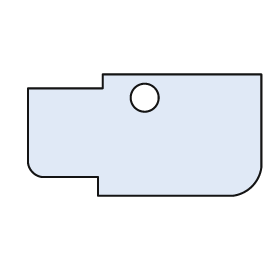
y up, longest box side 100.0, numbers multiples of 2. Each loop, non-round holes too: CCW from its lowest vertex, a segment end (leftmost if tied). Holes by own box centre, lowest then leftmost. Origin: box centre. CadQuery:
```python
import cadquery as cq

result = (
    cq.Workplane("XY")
    .moveTo(-20.0, -26.0)
    .lineTo(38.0, -26.0)
    .threePointArc((46.0, -22.0), (50.0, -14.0))
    .lineTo(50.0, 26.0)
    .lineTo(-18.0, 26.0)
    .lineTo(-18.0, 20.0)
    .lineTo(-50.0, 20.0)
    .lineTo(-50.0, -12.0)
    .threePointArc((-48.0, -16.0), (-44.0, -18.0))
    .lineTo(-20.0, -18.0)
    .close()
    .moveTo(0.0, 16.0)
    .circle(6.0)
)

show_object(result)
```